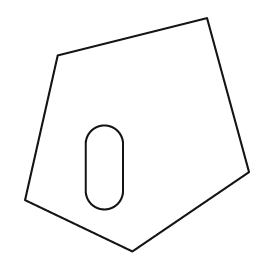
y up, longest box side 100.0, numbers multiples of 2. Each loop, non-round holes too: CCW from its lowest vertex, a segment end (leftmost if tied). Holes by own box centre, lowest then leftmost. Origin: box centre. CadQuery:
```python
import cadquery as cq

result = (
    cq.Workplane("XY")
    .moveTo(-2.0, -50.0)
    .lineTo(48.0, -16.0)
    .lineTo(30.0, 50.0)
    .lineTo(-34.0, 34.0)
    .lineTo(-48.0, -28.0)
    .close()
    .moveTo(-22.0, -24.0)
    .threePointArc((-14.0, -32.0), (-6.0, -24.0))
    .lineTo(-6.0, -4.0)
    .threePointArc((-14.0, 4.0), (-22.0, -4.0))
    .close()
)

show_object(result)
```